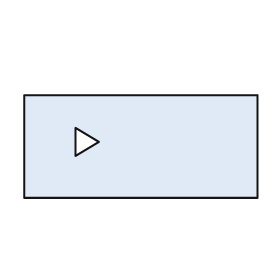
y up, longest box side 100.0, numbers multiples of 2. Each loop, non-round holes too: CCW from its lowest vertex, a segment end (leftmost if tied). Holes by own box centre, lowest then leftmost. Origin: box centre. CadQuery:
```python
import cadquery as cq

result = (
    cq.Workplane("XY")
    .moveTo(-50.0, -22.0)
    .lineTo(50.0, -22.0)
    .lineTo(50.0, 22.0)
    .lineTo(-50.0, 22.0)
    .close()
    .moveTo(-28.0, -4.0)
    .lineTo(-18.0, 2.0)
    .lineTo(-28.0, 8.0)
    .close()
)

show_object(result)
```